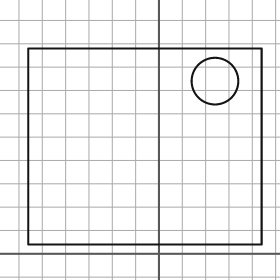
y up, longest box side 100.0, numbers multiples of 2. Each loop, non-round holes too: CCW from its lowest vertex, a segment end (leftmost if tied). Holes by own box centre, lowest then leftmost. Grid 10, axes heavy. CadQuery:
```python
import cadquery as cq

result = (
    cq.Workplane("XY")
    .moveTo(-56.0, 4.0)
    .lineTo(44.0, 4.0)
    .lineTo(44.0, 88.0)
    .lineTo(-56.0, 88.0)
    .close()
    .moveTo(24.0, 74.0)
    .circle(10.0)
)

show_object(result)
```